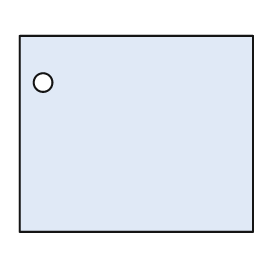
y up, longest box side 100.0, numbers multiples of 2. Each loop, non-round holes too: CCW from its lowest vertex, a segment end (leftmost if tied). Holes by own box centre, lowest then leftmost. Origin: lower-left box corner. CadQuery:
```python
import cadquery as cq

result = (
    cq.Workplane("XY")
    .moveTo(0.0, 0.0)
    .lineTo(100.0, 0.0)
    .lineTo(100.0, 84.0)
    .lineTo(0.0, 84.0)
    .close()
    .moveTo(10.0, 64.0)
    .circle(4.0)
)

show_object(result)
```